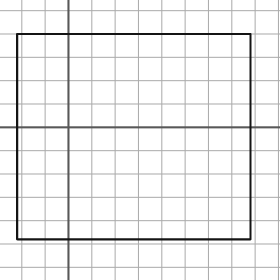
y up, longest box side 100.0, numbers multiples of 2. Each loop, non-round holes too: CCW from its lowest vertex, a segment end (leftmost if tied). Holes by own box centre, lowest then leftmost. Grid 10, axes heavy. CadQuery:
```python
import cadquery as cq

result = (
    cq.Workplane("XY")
    .moveTo(-22.0, -48.0)
    .lineTo(78.0, -48.0)
    .lineTo(78.0, 40.0)
    .lineTo(-22.0, 40.0)
    .close()
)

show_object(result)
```